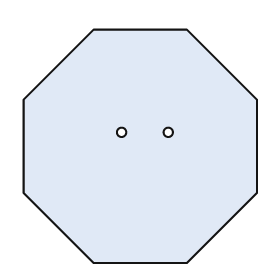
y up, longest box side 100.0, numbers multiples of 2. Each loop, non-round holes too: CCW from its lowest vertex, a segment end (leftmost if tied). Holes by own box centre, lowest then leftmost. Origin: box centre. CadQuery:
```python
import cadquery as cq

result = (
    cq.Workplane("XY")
    .moveTo(-20.0, -50.0)
    .lineTo(20.0, -50.0)
    .lineTo(50.0, -20.0)
    .lineTo(50.0, 20.0)
    .lineTo(20.0, 50.0)
    .lineTo(-20.0, 50.0)
    .lineTo(-50.0, 20.0)
    .lineTo(-50.0, -20.0)
    .close()
    .moveTo(-8.0, 6.0)
    .circle(2.0)
    .moveTo(12.0, 6.0)
    .circle(2.0)
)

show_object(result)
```